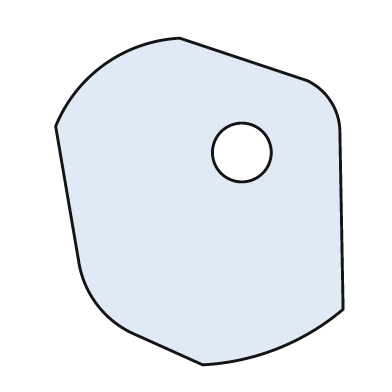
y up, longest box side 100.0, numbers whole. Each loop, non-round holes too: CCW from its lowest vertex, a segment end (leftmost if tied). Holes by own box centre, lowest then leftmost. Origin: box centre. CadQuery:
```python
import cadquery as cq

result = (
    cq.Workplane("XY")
    .moveTo(1.0, -50.0)
    .threePointArc((24.0, -45.0), (44.0, -33.0))
    .lineTo(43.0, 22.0)
    .threePointArc((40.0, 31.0), (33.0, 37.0))
    .lineTo(-6.0, 50.0)
    .threePointArc((-29.0, 42.0), (-44.0, 23.0))
    .lineTo(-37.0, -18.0)
    .threePointArc((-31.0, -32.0), (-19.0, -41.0))
    .close()
    .moveTo(13.0, 15.0)
    .circle(9.0)
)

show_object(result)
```